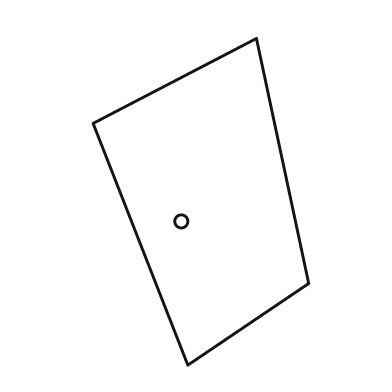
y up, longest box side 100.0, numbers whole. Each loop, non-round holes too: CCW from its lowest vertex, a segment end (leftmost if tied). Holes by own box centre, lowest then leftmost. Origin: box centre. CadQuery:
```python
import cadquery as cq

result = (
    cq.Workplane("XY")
    .moveTo(-4.0, -50.0)
    .lineTo(33.0, -25.0)
    .lineTo(17.0, 50.0)
    .lineTo(-33.0, 24.0)
    .close()
    .moveTo(-6.0, -6.0)
    .circle(2.0)
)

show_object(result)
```